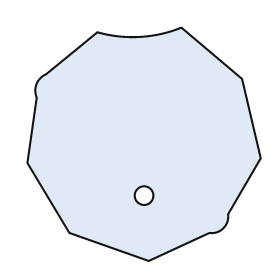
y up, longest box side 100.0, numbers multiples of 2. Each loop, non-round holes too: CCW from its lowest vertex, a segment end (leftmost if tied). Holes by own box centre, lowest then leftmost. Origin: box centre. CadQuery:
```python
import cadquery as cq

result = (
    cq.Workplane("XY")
    .moveTo(2.0, -50.0)
    .lineTo(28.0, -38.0)
    .threePointArc((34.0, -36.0), (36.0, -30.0))
    .lineTo(50.0, -6.0)
    .lineTo(42.0, 28.0)
    .lineTo(16.0, 50.0)
    .threePointArc((-2.0, 46.0), (-20.0, 48.0))
    .lineTo(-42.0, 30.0)
    .threePointArc((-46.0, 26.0), (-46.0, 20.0))
    .lineTo(-50.0, -8.0)
    .lineTo(-32.0, -38.0)
    .close()
    .moveTo(0.0, -22.0)
    .circle(4.0)
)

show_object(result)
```